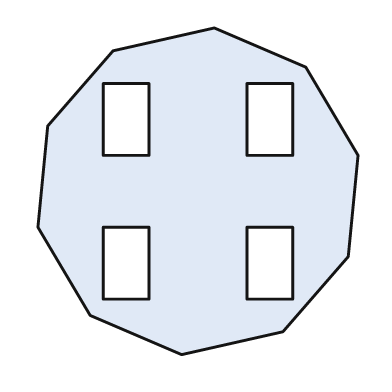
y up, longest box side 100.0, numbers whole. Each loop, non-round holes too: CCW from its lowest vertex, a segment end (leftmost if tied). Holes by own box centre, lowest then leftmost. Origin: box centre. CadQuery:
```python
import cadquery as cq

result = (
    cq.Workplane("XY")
    .moveTo(-5.0, -50.0)
    .lineTo(26.0, -43.0)
    .lineTo(46.0, -20.0)
    .lineTo(49.0, 11.0)
    .lineTo(33.0, 38.0)
    .lineTo(5.0, 50.0)
    .lineTo(-26.0, 43.0)
    .lineTo(-46.0, 20.0)
    .lineTo(-49.0, -11.0)
    .lineTo(-33.0, -38.0)
    .close()
    .moveTo(-29.0, -33.0)
    .lineTo(-15.0, -33.0)
    .lineTo(-15.0, -11.0)
    .lineTo(-29.0, -11.0)
    .close()
    .moveTo(15.0, -33.0)
    .lineTo(29.0, -33.0)
    .lineTo(29.0, -11.0)
    .lineTo(15.0, -11.0)
    .close()
    .moveTo(-29.0, 11.0)
    .lineTo(-15.0, 11.0)
    .lineTo(-15.0, 33.0)
    .lineTo(-29.0, 33.0)
    .close()
    .moveTo(15.0, 11.0)
    .lineTo(29.0, 11.0)
    .lineTo(29.0, 33.0)
    .lineTo(15.0, 33.0)
    .close()
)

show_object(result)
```